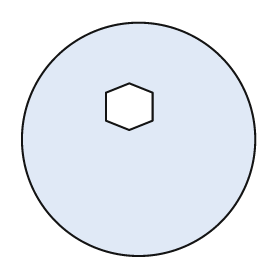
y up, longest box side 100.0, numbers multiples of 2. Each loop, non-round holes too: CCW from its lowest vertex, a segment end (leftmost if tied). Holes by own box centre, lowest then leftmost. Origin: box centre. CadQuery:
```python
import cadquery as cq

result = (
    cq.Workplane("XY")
    .moveTo(0.0, 0.0)
    .circle(50.0)
    .moveTo(-4.0, 4.0)
    .lineTo(6.0, 8.0)
    .lineTo(6.0, 20.0)
    .lineTo(-4.0, 24.0)
    .lineTo(-14.0, 20.0)
    .lineTo(-14.0, 8.0)
    .close()
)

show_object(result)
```